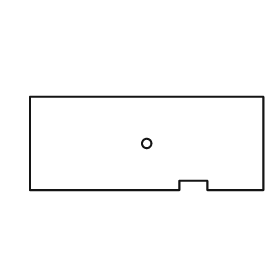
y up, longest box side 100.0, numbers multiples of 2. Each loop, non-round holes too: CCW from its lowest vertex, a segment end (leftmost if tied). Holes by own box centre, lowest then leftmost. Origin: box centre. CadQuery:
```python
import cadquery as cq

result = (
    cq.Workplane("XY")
    .moveTo(-50.0, -20.0)
    .lineTo(14.0, -20.0)
    .lineTo(14.0, -16.0)
    .lineTo(26.0, -16.0)
    .lineTo(26.0, -20.0)
    .lineTo(50.0, -20.0)
    .lineTo(50.0, 20.0)
    .lineTo(-50.0, 20.0)
    .close()
    .moveTo(0.0, 0.0)
    .circle(2.0)
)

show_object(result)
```